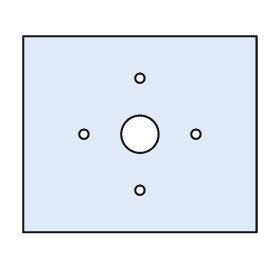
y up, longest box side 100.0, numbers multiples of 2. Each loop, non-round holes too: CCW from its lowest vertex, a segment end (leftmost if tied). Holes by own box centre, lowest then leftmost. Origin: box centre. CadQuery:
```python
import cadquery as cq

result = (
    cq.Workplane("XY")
    .moveTo(-50.0, -42.0)
    .lineTo(50.0, -42.0)
    .lineTo(50.0, 42.0)
    .lineTo(-50.0, 42.0)
    .close()
    .moveTo(0.0, -24.0)
    .circle(2.0)
    .moveTo(-24.0, 0.0)
    .circle(2.0)
    .moveTo(0.0, 0.0)
    .circle(8.0)
    .moveTo(24.0, 0.0)
    .circle(2.0)
    .moveTo(0.0, 24.0)
    .circle(2.0)
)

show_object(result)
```